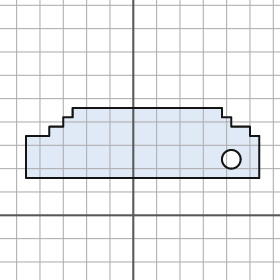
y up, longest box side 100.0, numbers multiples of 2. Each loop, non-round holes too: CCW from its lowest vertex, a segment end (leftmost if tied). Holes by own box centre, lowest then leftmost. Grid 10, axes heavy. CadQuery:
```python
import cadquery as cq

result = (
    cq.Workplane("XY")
    .moveTo(-46.0, 16.0)
    .lineTo(54.0, 16.0)
    .lineTo(54.0, 34.0)
    .lineTo(50.0, 34.0)
    .lineTo(50.0, 38.0)
    .lineTo(42.0, 38.0)
    .lineTo(42.0, 42.0)
    .lineTo(38.0, 42.0)
    .lineTo(38.0, 46.0)
    .lineTo(-26.0, 46.0)
    .lineTo(-26.0, 42.0)
    .lineTo(-30.0, 42.0)
    .lineTo(-30.0, 38.0)
    .lineTo(-36.0, 38.0)
    .lineTo(-36.0, 34.0)
    .lineTo(-46.0, 34.0)
    .close()
    .moveTo(42.0, 24.0)
    .circle(4.0)
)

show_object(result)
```